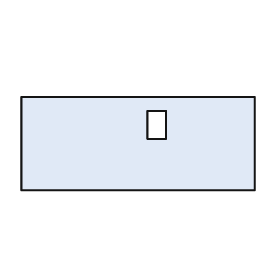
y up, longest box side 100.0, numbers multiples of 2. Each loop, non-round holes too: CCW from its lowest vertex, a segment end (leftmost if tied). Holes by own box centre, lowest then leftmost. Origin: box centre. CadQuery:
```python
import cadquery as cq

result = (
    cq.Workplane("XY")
    .moveTo(-50.0, -20.0)
    .lineTo(50.0, -20.0)
    .lineTo(50.0, 20.0)
    .lineTo(-50.0, 20.0)
    .close()
    .moveTo(4.0, 2.0)
    .lineTo(12.0, 2.0)
    .lineTo(12.0, 14.0)
    .lineTo(4.0, 14.0)
    .close()
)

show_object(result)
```